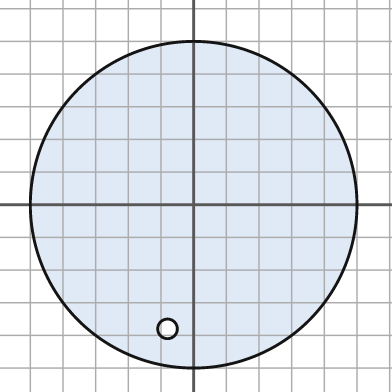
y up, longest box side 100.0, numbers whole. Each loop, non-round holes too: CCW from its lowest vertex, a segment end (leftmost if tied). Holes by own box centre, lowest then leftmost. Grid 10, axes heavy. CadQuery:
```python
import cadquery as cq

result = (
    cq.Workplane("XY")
    .moveTo(0.0, 0.0)
    .circle(50.0)
    .moveTo(-8.0, -38.0)
    .circle(3.0)
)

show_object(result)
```